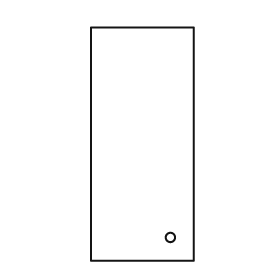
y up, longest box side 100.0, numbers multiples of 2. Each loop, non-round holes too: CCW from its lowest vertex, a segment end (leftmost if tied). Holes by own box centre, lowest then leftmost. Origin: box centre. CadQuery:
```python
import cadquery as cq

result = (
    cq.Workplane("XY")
    .moveTo(-22.0, -50.0)
    .lineTo(22.0, -50.0)
    .lineTo(22.0, 50.0)
    .lineTo(-22.0, 50.0)
    .close()
    .moveTo(12.0, -40.0)
    .circle(2.0)
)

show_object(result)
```